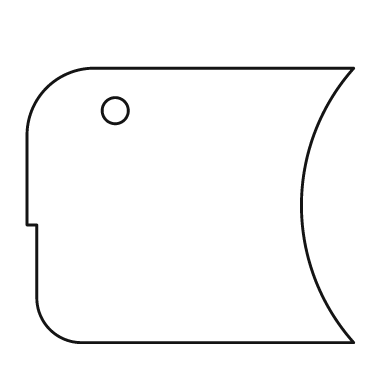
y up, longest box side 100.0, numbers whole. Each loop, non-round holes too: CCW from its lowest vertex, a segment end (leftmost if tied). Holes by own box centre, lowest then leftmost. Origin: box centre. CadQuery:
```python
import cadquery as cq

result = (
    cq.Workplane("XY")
    .moveTo(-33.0, -42.0)
    .lineTo(50.0, -42.0)
    .threePointArc((34.0, 0.0), (50.0, 42.0))
    .lineTo(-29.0, 42.0)
    .threePointArc((-44.0, 36.0), (-50.0, 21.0))
    .lineTo(-50.0, -6.0)
    .lineTo(-47.0, -6.0)
    .lineTo(-47.0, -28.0)
    .threePointArc((-43.0, -38.0), (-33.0, -42.0))
    .close()
    .moveTo(-23.0, 29.0)
    .circle(4.0)
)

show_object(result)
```